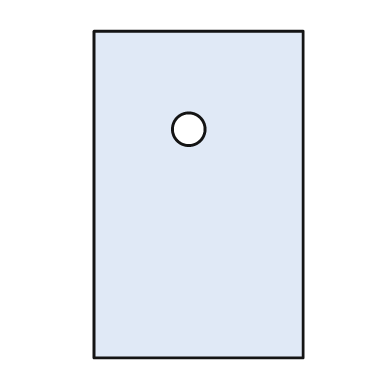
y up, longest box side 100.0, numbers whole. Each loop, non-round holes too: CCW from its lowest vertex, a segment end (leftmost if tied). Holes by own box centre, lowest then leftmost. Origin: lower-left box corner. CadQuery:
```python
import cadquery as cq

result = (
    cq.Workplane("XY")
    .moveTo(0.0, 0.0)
    .lineTo(64.0, 0.0)
    .lineTo(64.0, 100.0)
    .lineTo(0.0, 100.0)
    .close()
    .moveTo(29.0, 70.0)
    .circle(5.0)
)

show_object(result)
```